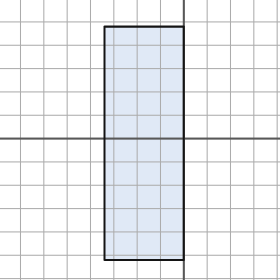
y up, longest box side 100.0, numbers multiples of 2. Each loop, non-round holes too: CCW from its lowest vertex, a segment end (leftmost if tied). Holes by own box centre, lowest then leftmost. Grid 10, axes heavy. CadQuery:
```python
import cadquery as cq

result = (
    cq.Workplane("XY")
    .moveTo(-34.0, -52.0)
    .lineTo(0.0, -52.0)
    .lineTo(0.0, 48.0)
    .lineTo(-34.0, 48.0)
    .close()
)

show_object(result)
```